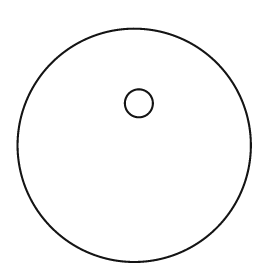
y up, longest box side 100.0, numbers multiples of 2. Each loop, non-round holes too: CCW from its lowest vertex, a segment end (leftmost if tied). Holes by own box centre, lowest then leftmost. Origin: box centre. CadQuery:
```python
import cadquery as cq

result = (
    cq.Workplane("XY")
    .moveTo(0.0, 0.0)
    .circle(50.0)
    .moveTo(2.0, 18.0)
    .circle(6.0)
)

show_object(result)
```